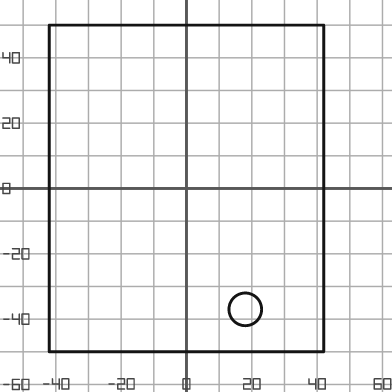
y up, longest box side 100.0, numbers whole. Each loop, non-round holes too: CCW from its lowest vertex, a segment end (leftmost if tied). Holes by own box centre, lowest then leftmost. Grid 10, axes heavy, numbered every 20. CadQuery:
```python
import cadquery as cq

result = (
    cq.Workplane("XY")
    .moveTo(-42.0, -50.0)
    .lineTo(42.0, -50.0)
    .lineTo(42.0, 50.0)
    .lineTo(-42.0, 50.0)
    .close()
    .moveTo(18.0, -37.0)
    .circle(5.0)
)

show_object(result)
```